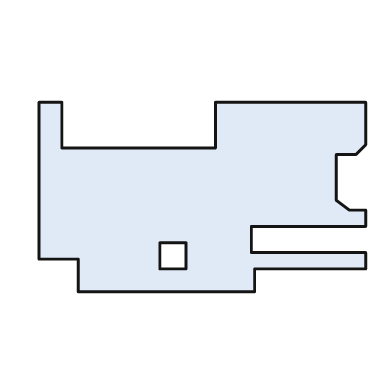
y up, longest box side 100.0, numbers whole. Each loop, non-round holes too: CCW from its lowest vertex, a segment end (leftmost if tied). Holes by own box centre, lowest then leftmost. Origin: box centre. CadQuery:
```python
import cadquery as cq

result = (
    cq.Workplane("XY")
    .moveTo(-38.0, -29.0)
    .lineTo(16.0, -29.0)
    .lineTo(16.0, -22.0)
    .lineTo(50.0, -22.0)
    .lineTo(50.0, -17.0)
    .lineTo(15.0, -17.0)
    .lineTo(15.0, -9.0)
    .lineTo(50.0, -9.0)
    .lineTo(50.0, -4.0)
    .lineTo(45.0, -4.0)
    .lineTo(41.0, -1.0)
    .lineTo(41.0, 13.0)
    .lineTo(47.0, 13.0)
    .lineTo(50.0, 16.0)
    .lineTo(50.0, 29.0)
    .lineTo(4.0, 29.0)
    .lineTo(4.0, 15.0)
    .lineTo(-43.0, 15.0)
    .lineTo(-43.0, 29.0)
    .lineTo(-50.0, 29.0)
    .lineTo(-50.0, -19.0)
    .lineTo(-38.0, -19.0)
    .close()
    .moveTo(-13.0, -22.0)
    .lineTo(-5.0, -22.0)
    .lineTo(-5.0, -14.0)
    .lineTo(-13.0, -14.0)
    .close()
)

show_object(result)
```